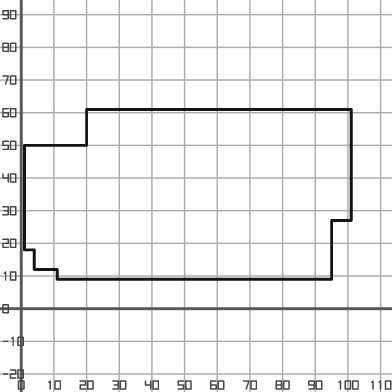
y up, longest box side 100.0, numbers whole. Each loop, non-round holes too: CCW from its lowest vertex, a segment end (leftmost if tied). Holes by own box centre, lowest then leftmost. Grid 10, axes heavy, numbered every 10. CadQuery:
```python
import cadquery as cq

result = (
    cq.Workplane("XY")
    .moveTo(11.0, 9.0)
    .lineTo(95.0, 9.0)
    .lineTo(95.0, 27.0)
    .lineTo(101.0, 27.0)
    .lineTo(101.0, 61.0)
    .lineTo(20.0, 61.0)
    .lineTo(20.0, 50.0)
    .lineTo(1.0, 50.0)
    .lineTo(1.0, 18.0)
    .lineTo(4.0, 18.0)
    .lineTo(4.0, 12.0)
    .lineTo(11.0, 12.0)
    .close()
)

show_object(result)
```